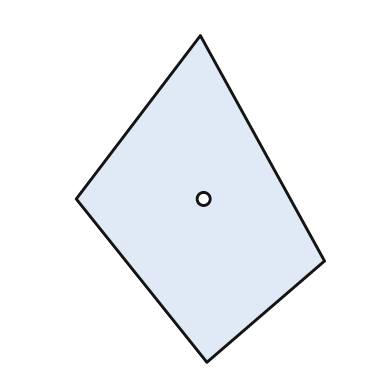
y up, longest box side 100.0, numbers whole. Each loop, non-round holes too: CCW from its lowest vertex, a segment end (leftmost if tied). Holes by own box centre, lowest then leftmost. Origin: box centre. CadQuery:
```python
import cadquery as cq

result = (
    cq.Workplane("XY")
    .moveTo(2.0, -50.0)
    .lineTo(38.0, -19.0)
    .lineTo(0.0, 50.0)
    .lineTo(-38.0, 0.0)
    .close()
    .moveTo(1.0, 0.0)
    .circle(2.0)
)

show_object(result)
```